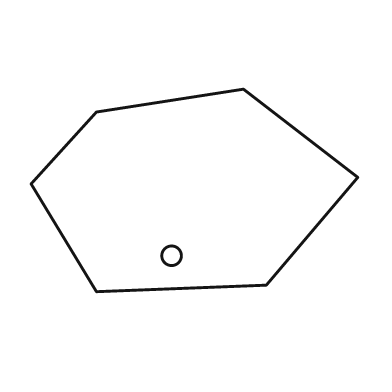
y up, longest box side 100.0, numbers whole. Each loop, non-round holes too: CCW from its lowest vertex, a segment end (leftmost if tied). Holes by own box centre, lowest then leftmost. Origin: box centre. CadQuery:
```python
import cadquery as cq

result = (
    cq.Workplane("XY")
    .moveTo(-30.0, -31.0)
    .lineTo(22.0, -29.0)
    .lineTo(50.0, 4.0)
    .lineTo(15.0, 31.0)
    .lineTo(-30.0, 24.0)
    .lineTo(-50.0, 2.0)
    .close()
    .moveTo(-7.0, -20.0)
    .circle(3.0)
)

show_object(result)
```